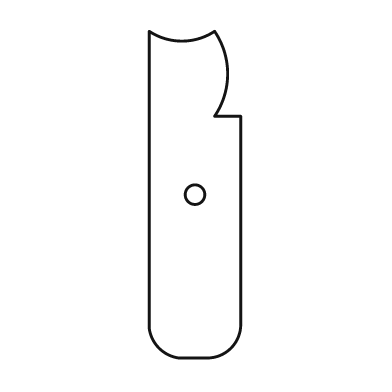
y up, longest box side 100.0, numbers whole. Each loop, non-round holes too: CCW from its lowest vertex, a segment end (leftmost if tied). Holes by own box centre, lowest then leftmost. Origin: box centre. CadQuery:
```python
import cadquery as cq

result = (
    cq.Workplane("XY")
    .moveTo(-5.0, -50.0)
    .lineTo(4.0, -50.0)
    .threePointArc((11.0, -47.0), (14.0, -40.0))
    .lineTo(14.0, 24.0)
    .lineTo(6.0, 24.0)
    .threePointArc((10.0, 37.0), (6.0, 50.0))
    .threePointArc((-4.0, 47.0), (-14.0, 50.0))
    .lineTo(-14.0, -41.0)
    .threePointArc((-11.0, -47.0), (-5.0, -50.0))
    .close()
    .moveTo(0.0, 0.0)
    .circle(3.0)
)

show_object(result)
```